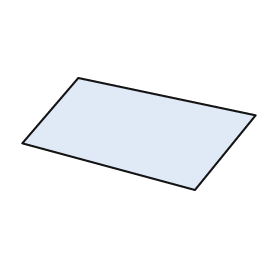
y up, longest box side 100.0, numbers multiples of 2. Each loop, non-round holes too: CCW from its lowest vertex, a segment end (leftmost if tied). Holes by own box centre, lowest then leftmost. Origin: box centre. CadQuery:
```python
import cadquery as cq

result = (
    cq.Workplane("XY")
    .moveTo(24.0, -24.0)
    .lineTo(50.0, 8.0)
    .lineTo(-26.0, 24.0)
    .lineTo(-50.0, -4.0)
    .close()
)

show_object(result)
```